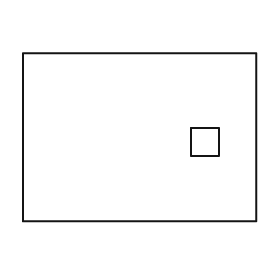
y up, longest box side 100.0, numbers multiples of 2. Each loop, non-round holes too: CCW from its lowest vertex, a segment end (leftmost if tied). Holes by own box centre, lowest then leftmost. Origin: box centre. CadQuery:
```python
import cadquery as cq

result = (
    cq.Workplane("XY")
    .moveTo(-50.0, -36.0)
    .lineTo(50.0, -36.0)
    .lineTo(50.0, 36.0)
    .lineTo(-50.0, 36.0)
    .close()
    .moveTo(22.0, -8.0)
    .lineTo(34.0, -8.0)
    .lineTo(34.0, 4.0)
    .lineTo(22.0, 4.0)
    .close()
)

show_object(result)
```